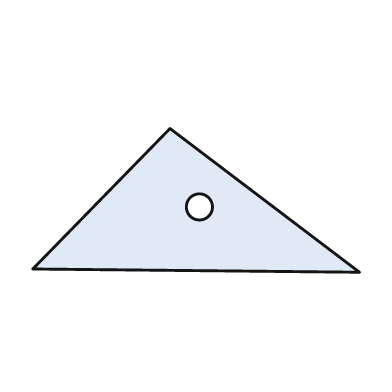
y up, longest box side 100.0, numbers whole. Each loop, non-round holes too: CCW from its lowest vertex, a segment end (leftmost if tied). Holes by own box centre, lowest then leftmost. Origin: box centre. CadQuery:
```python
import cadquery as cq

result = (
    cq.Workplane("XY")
    .moveTo(50.0, -22.0)
    .lineTo(-8.0, 22.0)
    .lineTo(-50.0, -21.0)
    .close()
    .moveTo(1.0, -2.0)
    .circle(4.0)
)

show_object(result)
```